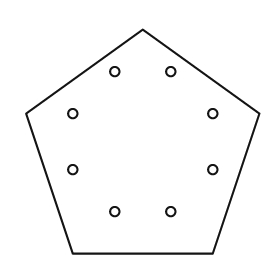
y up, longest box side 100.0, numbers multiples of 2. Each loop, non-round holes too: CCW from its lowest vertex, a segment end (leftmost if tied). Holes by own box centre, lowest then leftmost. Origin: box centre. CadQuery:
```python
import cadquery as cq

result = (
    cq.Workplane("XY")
    .moveTo(-30.0, -48.0)
    .lineTo(30.0, -48.0)
    .lineTo(50.0, 12.0)
    .lineTo(0.0, 48.0)
    .lineTo(-50.0, 12.0)
    .close()
    .moveTo(-12.0, -30.0)
    .circle(2.0)
    .moveTo(12.0, -30.0)
    .circle(2.0)
    .moveTo(-30.0, -12.0)
    .circle(2.0)
    .moveTo(30.0, -12.0)
    .circle(2.0)
    .moveTo(-30.0, 12.0)
    .circle(2.0)
    .moveTo(30.0, 12.0)
    .circle(2.0)
    .moveTo(-12.0, 30.0)
    .circle(2.0)
    .moveTo(12.0, 30.0)
    .circle(2.0)
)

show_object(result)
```